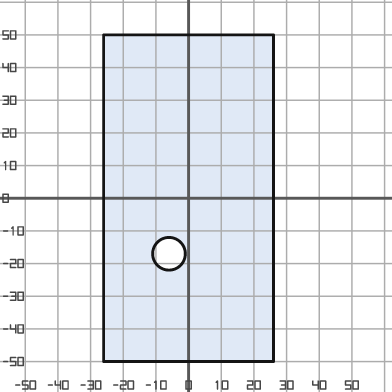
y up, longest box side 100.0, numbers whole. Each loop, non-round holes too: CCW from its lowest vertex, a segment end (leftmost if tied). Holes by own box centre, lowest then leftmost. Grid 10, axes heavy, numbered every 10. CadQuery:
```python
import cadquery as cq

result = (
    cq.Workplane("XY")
    .moveTo(-26.0, -50.0)
    .lineTo(26.0, -50.0)
    .lineTo(26.0, 50.0)
    .lineTo(-26.0, 50.0)
    .close()
    .moveTo(-6.0, -17.0)
    .circle(5.0)
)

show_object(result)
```